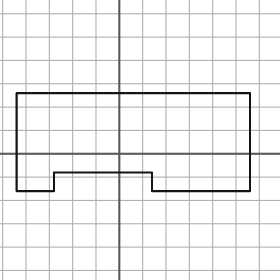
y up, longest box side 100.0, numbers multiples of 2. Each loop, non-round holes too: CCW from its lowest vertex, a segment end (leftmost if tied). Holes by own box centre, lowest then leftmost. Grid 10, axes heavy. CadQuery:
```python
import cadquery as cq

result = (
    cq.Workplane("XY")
    .moveTo(-44.0, -16.0)
    .lineTo(-28.0, -16.0)
    .lineTo(-28.0, -8.0)
    .lineTo(14.0, -8.0)
    .lineTo(14.0, -16.0)
    .lineTo(56.0, -16.0)
    .lineTo(56.0, 26.0)
    .lineTo(-44.0, 26.0)
    .close()
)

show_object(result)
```